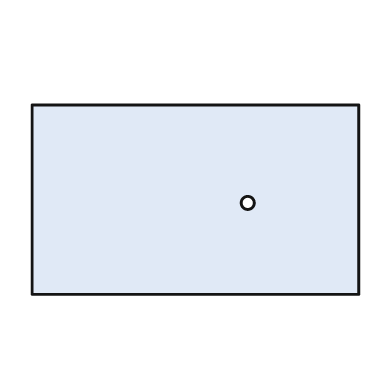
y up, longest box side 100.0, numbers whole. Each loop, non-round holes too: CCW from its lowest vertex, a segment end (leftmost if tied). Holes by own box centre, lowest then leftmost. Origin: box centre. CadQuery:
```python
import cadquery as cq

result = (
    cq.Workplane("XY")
    .moveTo(-50.0, -29.0)
    .lineTo(50.0, -29.0)
    .lineTo(50.0, 29.0)
    .lineTo(-50.0, 29.0)
    .close()
    .moveTo(16.0, -1.0)
    .circle(2.0)
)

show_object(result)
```